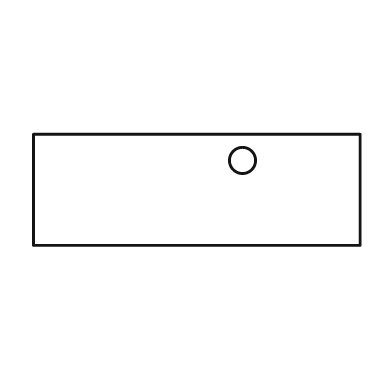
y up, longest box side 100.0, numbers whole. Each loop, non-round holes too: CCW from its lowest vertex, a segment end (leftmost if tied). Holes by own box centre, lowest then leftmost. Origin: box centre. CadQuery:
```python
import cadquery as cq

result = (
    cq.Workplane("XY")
    .moveTo(-50.0, -17.0)
    .lineTo(50.0, -17.0)
    .lineTo(50.0, 17.0)
    .lineTo(-50.0, 17.0)
    .close()
    .moveTo(14.0, 9.0)
    .circle(4.0)
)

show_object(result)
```